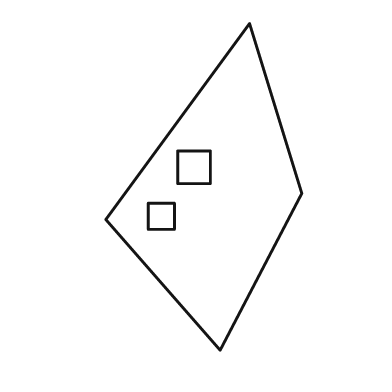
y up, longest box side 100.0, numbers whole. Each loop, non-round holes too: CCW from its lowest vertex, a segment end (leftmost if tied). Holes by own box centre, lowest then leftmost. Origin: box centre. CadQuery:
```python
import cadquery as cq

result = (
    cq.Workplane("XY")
    .moveTo(5.0, -50.0)
    .lineTo(30.0, -2.0)
    .lineTo(14.0, 50.0)
    .lineTo(-30.0, -10.0)
    .close()
    .moveTo(-17.0, -13.0)
    .lineTo(-9.0, -13.0)
    .lineTo(-9.0, -5.0)
    .lineTo(-17.0, -5.0)
    .close()
    .moveTo(-8.0, 1.0)
    .lineTo(2.0, 1.0)
    .lineTo(2.0, 11.0)
    .lineTo(-8.0, 11.0)
    .close()
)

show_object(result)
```